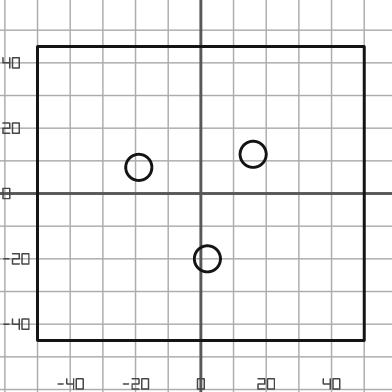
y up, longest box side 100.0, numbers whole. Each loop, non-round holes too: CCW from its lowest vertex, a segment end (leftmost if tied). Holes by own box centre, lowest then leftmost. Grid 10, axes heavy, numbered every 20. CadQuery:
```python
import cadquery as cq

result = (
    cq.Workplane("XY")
    .moveTo(-50.0, -45.0)
    .lineTo(50.0, -45.0)
    .lineTo(50.0, 45.0)
    .lineTo(-50.0, 45.0)
    .close()
    .moveTo(2.0, -20.0)
    .circle(4.0)
    .moveTo(-19.0, 8.0)
    .circle(4.0)
    .moveTo(16.0, 12.0)
    .circle(4.0)
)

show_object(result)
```